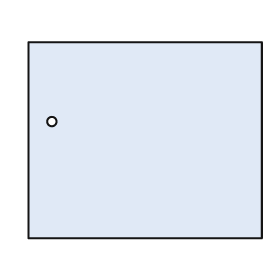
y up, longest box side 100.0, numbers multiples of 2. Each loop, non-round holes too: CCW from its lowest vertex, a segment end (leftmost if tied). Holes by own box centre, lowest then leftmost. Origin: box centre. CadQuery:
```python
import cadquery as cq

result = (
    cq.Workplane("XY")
    .moveTo(-50.0, -42.0)
    .lineTo(50.0, -42.0)
    .lineTo(50.0, 42.0)
    .lineTo(-50.0, 42.0)
    .close()
    .moveTo(-40.0, 8.0)
    .circle(2.0)
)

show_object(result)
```